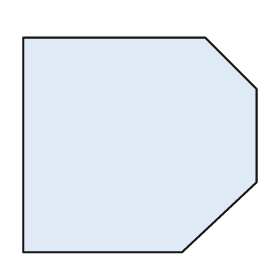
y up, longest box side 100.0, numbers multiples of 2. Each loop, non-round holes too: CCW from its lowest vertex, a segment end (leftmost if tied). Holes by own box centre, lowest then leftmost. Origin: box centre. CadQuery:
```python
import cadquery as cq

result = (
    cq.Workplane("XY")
    .moveTo(-50.0, -46.0)
    .lineTo(18.0, -46.0)
    .lineTo(50.0, -16.0)
    .lineTo(50.0, 24.0)
    .lineTo(28.0, 46.0)
    .lineTo(-50.0, 46.0)
    .close()
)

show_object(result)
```